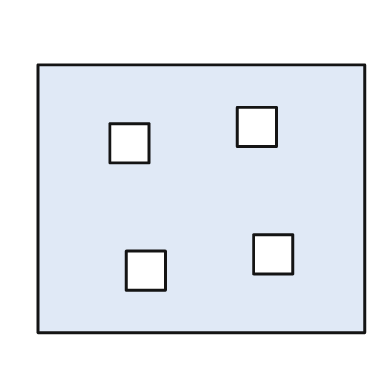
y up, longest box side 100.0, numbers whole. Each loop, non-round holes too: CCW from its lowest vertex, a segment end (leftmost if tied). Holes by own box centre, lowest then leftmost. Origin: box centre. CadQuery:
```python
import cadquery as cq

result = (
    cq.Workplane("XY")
    .moveTo(-50.0, -41.0)
    .lineTo(50.0, -41.0)
    .lineTo(50.0, 41.0)
    .lineTo(-50.0, 41.0)
    .close()
    .moveTo(-23.0, -28.0)
    .lineTo(-11.0, -28.0)
    .lineTo(-11.0, -16.0)
    .lineTo(-23.0, -16.0)
    .close()
    .moveTo(16.0, -23.0)
    .lineTo(28.0, -23.0)
    .lineTo(28.0, -11.0)
    .lineTo(16.0, -11.0)
    .close()
    .moveTo(-28.0, 11.0)
    .lineTo(-16.0, 11.0)
    .lineTo(-16.0, 23.0)
    .lineTo(-28.0, 23.0)
    .close()
    .moveTo(11.0, 16.0)
    .lineTo(23.0, 16.0)
    .lineTo(23.0, 28.0)
    .lineTo(11.0, 28.0)
    .close()
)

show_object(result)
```